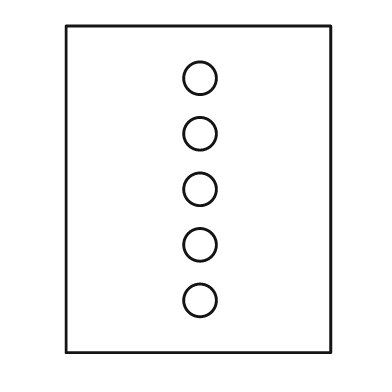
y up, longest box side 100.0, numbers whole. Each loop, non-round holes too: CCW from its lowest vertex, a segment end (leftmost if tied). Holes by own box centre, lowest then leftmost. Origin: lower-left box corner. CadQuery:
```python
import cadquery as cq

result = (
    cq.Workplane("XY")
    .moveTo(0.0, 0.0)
    .lineTo(81.0, 0.0)
    .lineTo(81.0, 100.0)
    .lineTo(0.0, 100.0)
    .close()
    .moveTo(41.0, 16.0)
    .circle(5.0)
    .moveTo(41.0, 33.0)
    .circle(5.0)
    .moveTo(41.0, 50.0)
    .circle(5.0)
    .moveTo(41.0, 67.0)
    .circle(5.0)
    .moveTo(41.0, 84.0)
    .circle(5.0)
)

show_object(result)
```